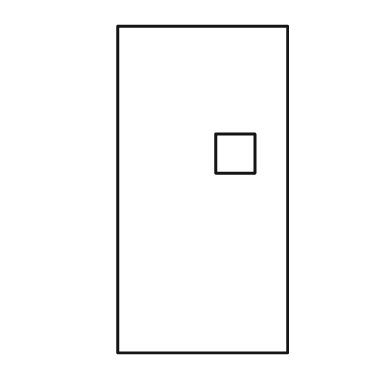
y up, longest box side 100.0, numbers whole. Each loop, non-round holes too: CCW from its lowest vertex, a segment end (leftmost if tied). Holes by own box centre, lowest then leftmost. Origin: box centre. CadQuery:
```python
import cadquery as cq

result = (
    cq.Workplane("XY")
    .moveTo(-26.0, -50.0)
    .lineTo(26.0, -50.0)
    .lineTo(26.0, 50.0)
    .lineTo(-26.0, 50.0)
    .close()
    .moveTo(4.0, 5.0)
    .lineTo(16.0, 5.0)
    .lineTo(16.0, 17.0)
    .lineTo(4.0, 17.0)
    .close()
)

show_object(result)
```